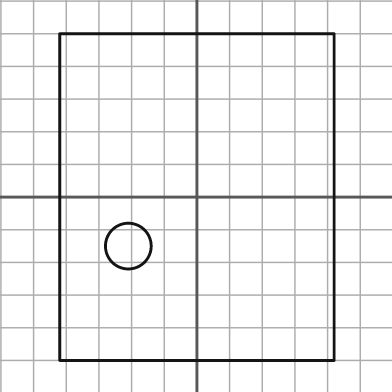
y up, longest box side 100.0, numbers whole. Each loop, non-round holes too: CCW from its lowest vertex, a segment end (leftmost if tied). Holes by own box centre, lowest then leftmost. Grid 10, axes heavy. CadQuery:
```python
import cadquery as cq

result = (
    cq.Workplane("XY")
    .moveTo(-42.0, -50.0)
    .lineTo(42.0, -50.0)
    .lineTo(42.0, 50.0)
    .lineTo(-42.0, 50.0)
    .close()
    .moveTo(-21.0, -15.0)
    .circle(7.0)
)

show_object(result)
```